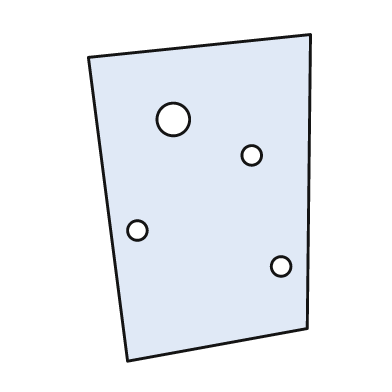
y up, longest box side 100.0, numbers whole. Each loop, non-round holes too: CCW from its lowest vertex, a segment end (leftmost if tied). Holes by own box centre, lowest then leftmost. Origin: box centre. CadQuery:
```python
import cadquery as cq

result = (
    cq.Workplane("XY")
    .moveTo(-22.0, -50.0)
    .lineTo(33.0, -40.0)
    .lineTo(34.0, 50.0)
    .lineTo(-34.0, 43.0)
    .close()
    .moveTo(25.0, -21.0)
    .circle(3.0)
    .moveTo(-19.0, -10.0)
    .circle(3.0)
    .moveTo(16.0, 13.0)
    .circle(3.0)
    .moveTo(-8.0, 24.0)
    .circle(5.0)
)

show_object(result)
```